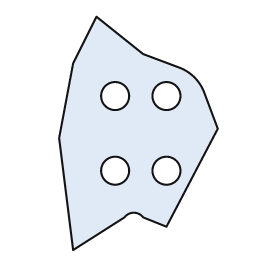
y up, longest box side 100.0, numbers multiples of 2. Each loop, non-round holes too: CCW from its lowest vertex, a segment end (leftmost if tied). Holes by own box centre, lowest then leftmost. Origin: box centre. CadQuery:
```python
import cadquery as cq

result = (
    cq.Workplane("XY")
    .moveTo(-28.0, -50.0)
    .lineTo(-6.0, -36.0)
    .threePointArc((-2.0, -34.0), (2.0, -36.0))
    .lineTo(12.0, -40.0)
    .lineTo(34.0, 2.0)
    .lineTo(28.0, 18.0)
    .threePointArc((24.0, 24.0), (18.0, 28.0))
    .lineTo(2.0, 34.0)
    .lineTo(-18.0, 50.0)
    .lineTo(-28.0, 30.0)
    .lineTo(-34.0, -2.0)
    .close()
    .moveTo(-10.0, -16.0)
    .circle(6.0)
    .moveTo(12.0, -16.0)
    .circle(6.0)
    .moveTo(-10.0, 16.0)
    .circle(6.0)
    .moveTo(12.0, 16.0)
    .circle(6.0)
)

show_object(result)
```